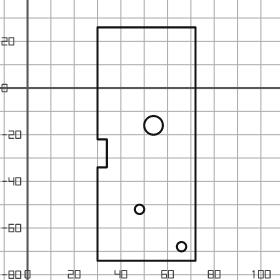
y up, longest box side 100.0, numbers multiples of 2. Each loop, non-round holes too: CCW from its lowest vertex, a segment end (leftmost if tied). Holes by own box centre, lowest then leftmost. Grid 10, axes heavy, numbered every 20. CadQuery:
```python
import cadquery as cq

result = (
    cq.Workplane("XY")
    .moveTo(30.0, -74.0)
    .lineTo(72.0, -74.0)
    .lineTo(72.0, 26.0)
    .lineTo(30.0, 26.0)
    .lineTo(30.0, -22.0)
    .lineTo(34.0, -22.0)
    .lineTo(34.0, -34.0)
    .lineTo(30.0, -34.0)
    .close()
    .moveTo(66.0, -68.0)
    .circle(2.0)
    .moveTo(48.0, -52.0)
    .circle(2.0)
    .moveTo(54.0, -16.0)
    .circle(4.0)
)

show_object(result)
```